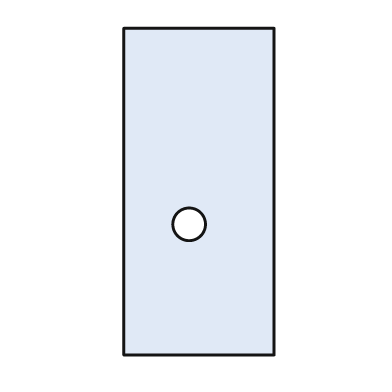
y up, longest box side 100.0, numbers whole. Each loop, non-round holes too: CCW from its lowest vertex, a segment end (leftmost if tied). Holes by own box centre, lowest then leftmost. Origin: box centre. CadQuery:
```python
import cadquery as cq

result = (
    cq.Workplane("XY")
    .moveTo(-23.0, -50.0)
    .lineTo(23.0, -50.0)
    .lineTo(23.0, 50.0)
    .lineTo(-23.0, 50.0)
    .close()
    .moveTo(-3.0, -10.0)
    .circle(5.0)
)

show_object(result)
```